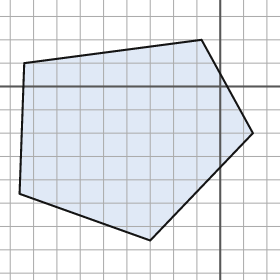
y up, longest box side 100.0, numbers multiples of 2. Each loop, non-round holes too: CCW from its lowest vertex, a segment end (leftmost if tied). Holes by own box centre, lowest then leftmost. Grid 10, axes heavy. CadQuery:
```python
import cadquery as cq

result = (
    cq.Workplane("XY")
    .moveTo(-30.0, -66.0)
    .lineTo(14.0, -20.0)
    .lineTo(-8.0, 20.0)
    .lineTo(-84.0, 10.0)
    .lineTo(-86.0, -46.0)
    .close()
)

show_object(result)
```